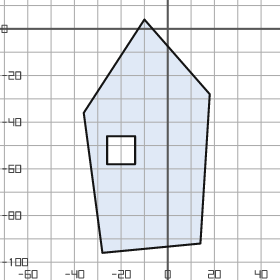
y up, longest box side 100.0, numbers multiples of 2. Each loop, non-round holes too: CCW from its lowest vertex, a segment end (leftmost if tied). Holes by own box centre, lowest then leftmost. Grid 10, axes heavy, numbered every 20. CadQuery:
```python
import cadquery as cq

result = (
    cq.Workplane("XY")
    .moveTo(-28.0, -96.0)
    .lineTo(14.0, -92.0)
    .lineTo(18.0, -28.0)
    .lineTo(-10.0, 4.0)
    .lineTo(-36.0, -36.0)
    .close()
    .moveTo(-26.0, -58.0)
    .lineTo(-14.0, -58.0)
    .lineTo(-14.0, -46.0)
    .lineTo(-26.0, -46.0)
    .close()
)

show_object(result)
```